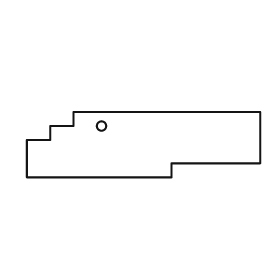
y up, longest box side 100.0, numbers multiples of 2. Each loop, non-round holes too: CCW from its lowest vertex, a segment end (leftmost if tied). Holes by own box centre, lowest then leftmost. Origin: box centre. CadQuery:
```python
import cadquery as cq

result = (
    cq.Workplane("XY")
    .moveTo(-50.0, -14.0)
    .lineTo(12.0, -14.0)
    .lineTo(12.0, -8.0)
    .lineTo(50.0, -8.0)
    .lineTo(50.0, 14.0)
    .lineTo(-30.0, 14.0)
    .lineTo(-30.0, 8.0)
    .lineTo(-40.0, 8.0)
    .lineTo(-40.0, 2.0)
    .lineTo(-50.0, 2.0)
    .close()
    .moveTo(-18.0, 8.0)
    .circle(2.0)
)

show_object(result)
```